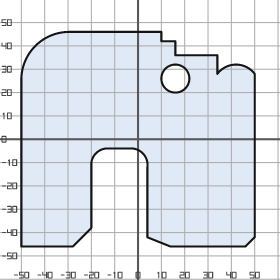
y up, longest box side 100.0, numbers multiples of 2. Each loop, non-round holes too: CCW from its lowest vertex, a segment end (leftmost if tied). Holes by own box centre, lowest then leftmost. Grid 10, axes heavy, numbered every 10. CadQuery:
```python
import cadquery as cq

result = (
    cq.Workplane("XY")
    .moveTo(-50.0, -46.0)
    .lineTo(-28.0, -46.0)
    .lineTo(-20.0, -38.0)
    .lineTo(-20.0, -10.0)
    .threePointArc((-18.0, -6.0), (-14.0, -4.0))
    .lineTo(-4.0, -4.0)
    .threePointArc((2.0, -6.0), (4.0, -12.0))
    .lineTo(4.0, -42.0)
    .lineTo(14.0, -46.0)
    .lineTo(46.0, -46.0)
    .lineTo(50.0, -42.0)
    .lineTo(50.0, 28.0)
    .threePointArc((42.0, 32.0), (34.0, 28.0))
    .lineTo(34.0, 36.0)
    .lineTo(16.0, 36.0)
    .lineTo(16.0, 42.0)
    .lineTo(10.0, 42.0)
    .lineTo(10.0, 46.0)
    .lineTo(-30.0, 46.0)
    .threePointArc((-44.0, 40.0), (-50.0, 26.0))
    .close()
    .moveTo(16.0, 26.0)
    .circle(6.0)
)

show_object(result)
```